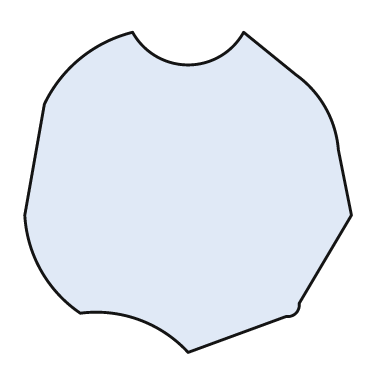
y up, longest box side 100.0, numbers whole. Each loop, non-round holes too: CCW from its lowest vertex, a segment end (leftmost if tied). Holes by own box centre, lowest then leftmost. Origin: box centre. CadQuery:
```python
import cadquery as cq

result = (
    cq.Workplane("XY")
    .moveTo(0.0, -49.0)
    .lineTo(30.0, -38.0)
    .threePointArc((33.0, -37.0), (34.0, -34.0))
    .lineTo(50.0, -7.0)
    .lineTo(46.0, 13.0)
    .threePointArc((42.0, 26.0), (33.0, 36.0))
    .lineTo(17.0, 49.0)
    .threePointArc((0.0, 39.0), (-17.0, 49.0))
    .threePointArc((-33.0, 41.0), (-44.0, 27.0))
    .lineTo(-50.0, -7.0)
    .threePointArc((-45.0, -24.0), (-33.0, -37.0))
    .threePointArc((-15.0, -39.0), (0.0, -49.0))
    .close()
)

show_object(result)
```